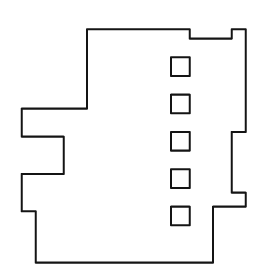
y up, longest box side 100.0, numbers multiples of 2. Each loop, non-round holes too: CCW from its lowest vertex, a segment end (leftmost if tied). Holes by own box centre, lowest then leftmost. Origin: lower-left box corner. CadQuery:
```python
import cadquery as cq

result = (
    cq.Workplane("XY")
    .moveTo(6.0, 0.0)
    .lineTo(82.0, 0.0)
    .lineTo(82.0, 24.0)
    .lineTo(96.0, 24.0)
    .lineTo(96.0, 30.0)
    .lineTo(90.0, 30.0)
    .lineTo(90.0, 56.0)
    .lineTo(96.0, 56.0)
    .lineTo(96.0, 100.0)
    .lineTo(90.0, 100.0)
    .lineTo(90.0, 96.0)
    .lineTo(72.0, 96.0)
    .lineTo(72.0, 100.0)
    .lineTo(28.0, 100.0)
    .lineTo(28.0, 66.0)
    .lineTo(0.0, 66.0)
    .lineTo(0.0, 54.0)
    .lineTo(18.0, 54.0)
    .lineTo(18.0, 38.0)
    .lineTo(0.0, 38.0)
    .lineTo(0.0, 22.0)
    .lineTo(6.0, 22.0)
    .close()
    .moveTo(64.0, 16.0)
    .lineTo(72.0, 16.0)
    .lineTo(72.0, 24.0)
    .lineTo(64.0, 24.0)
    .close()
    .moveTo(64.0, 32.0)
    .lineTo(72.0, 32.0)
    .lineTo(72.0, 40.0)
    .lineTo(64.0, 40.0)
    .close()
    .moveTo(64.0, 48.0)
    .lineTo(72.0, 48.0)
    .lineTo(72.0, 56.0)
    .lineTo(64.0, 56.0)
    .close()
    .moveTo(64.0, 64.0)
    .lineTo(72.0, 64.0)
    .lineTo(72.0, 72.0)
    .lineTo(64.0, 72.0)
    .close()
    .moveTo(64.0, 80.0)
    .lineTo(72.0, 80.0)
    .lineTo(72.0, 88.0)
    .lineTo(64.0, 88.0)
    .close()
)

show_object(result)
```